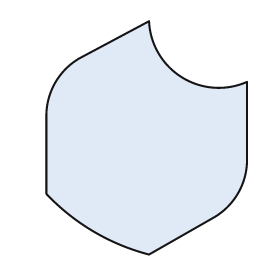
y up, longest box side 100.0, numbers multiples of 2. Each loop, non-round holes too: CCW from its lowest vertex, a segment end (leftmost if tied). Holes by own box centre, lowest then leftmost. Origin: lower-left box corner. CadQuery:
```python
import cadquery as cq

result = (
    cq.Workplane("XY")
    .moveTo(44.0, 0.0)
    .lineTo(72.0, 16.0)
    .threePointArc((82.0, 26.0), (86.0, 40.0))
    .lineTo(86.0, 74.0)
    .threePointArc((58.0, 76.0), (44.0, 100.0))
    .lineTo(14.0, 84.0)
    .threePointArc((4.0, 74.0), (0.0, 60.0))
    .lineTo(0.0, 26.0)
    .threePointArc((20.0, 10.0), (44.0, 0.0))
    .close()
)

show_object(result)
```